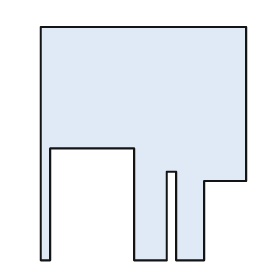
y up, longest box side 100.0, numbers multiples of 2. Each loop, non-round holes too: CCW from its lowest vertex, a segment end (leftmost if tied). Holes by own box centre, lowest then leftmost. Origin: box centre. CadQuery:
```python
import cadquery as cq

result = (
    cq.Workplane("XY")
    .moveTo(-44.0, -50.0)
    .lineTo(-40.0, -50.0)
    .lineTo(-40.0, -2.0)
    .lineTo(-4.0, -2.0)
    .lineTo(-4.0, -50.0)
    .lineTo(10.0, -50.0)
    .lineTo(10.0, -12.0)
    .lineTo(14.0, -12.0)
    .lineTo(14.0, -50.0)
    .lineTo(26.0, -50.0)
    .lineTo(26.0, -16.0)
    .lineTo(44.0, -16.0)
    .lineTo(44.0, 50.0)
    .lineTo(-44.0, 50.0)
    .close()
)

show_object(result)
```